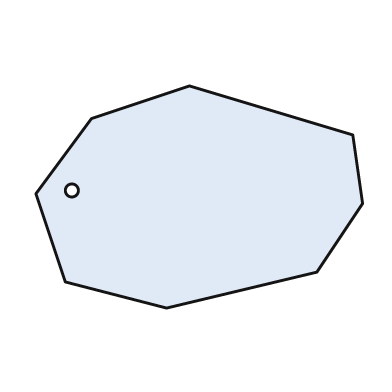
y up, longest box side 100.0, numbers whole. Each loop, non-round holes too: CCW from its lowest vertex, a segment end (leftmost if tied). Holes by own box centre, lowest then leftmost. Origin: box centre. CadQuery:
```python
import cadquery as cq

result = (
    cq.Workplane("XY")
    .moveTo(-10.0, -34.0)
    .lineTo(36.0, -23.0)
    .lineTo(50.0, -2.0)
    .lineTo(47.0, 19.0)
    .lineTo(-3.0, 34.0)
    .lineTo(-33.0, 24.0)
    .lineTo(-50.0, 1.0)
    .lineTo(-41.0, -26.0)
    .close()
    .moveTo(-39.0, 2.0)
    .circle(2.0)
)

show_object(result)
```